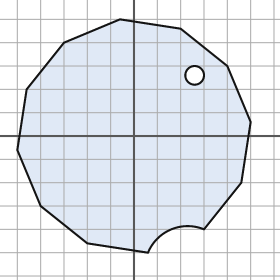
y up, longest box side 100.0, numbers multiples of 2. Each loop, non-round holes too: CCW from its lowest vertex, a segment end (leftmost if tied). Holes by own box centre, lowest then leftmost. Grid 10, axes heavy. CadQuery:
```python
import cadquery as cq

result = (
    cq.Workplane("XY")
    .moveTo(6.0, -50.0)
    .threePointArc((16.0, -40.0), (30.0, -40.0))
    .lineTo(46.0, -20.0)
    .lineTo(50.0, 6.0)
    .lineTo(40.0, 30.0)
    .lineTo(20.0, 46.0)
    .lineTo(-6.0, 50.0)
    .lineTo(-30.0, 40.0)
    .lineTo(-46.0, 20.0)
    .lineTo(-50.0, -6.0)
    .lineTo(-40.0, -30.0)
    .lineTo(-20.0, -46.0)
    .close()
    .moveTo(26.0, 26.0)
    .circle(4.0)
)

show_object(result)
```